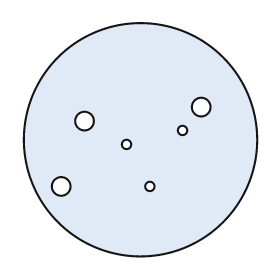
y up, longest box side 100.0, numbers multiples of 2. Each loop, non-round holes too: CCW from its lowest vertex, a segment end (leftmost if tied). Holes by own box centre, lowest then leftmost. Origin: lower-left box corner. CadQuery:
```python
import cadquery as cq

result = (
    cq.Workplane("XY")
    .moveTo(50.0, 50.0)
    .circle(50.0)
    .moveTo(16.0, 30.0)
    .circle(4.0)
    .moveTo(54.0, 30.0)
    .circle(2.0)
    .moveTo(44.0, 48.0)
    .circle(2.0)
    .moveTo(68.0, 54.0)
    .circle(2.0)
    .moveTo(26.0, 58.0)
    .circle(4.0)
    .moveTo(76.0, 64.0)
    .circle(4.0)
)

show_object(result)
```